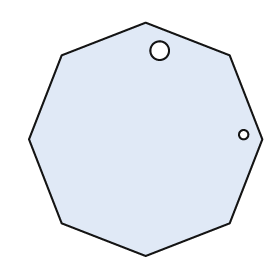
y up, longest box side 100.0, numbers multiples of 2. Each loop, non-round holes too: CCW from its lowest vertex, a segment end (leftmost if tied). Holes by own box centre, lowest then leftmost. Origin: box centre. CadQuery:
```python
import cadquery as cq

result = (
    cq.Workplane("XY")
    .moveTo(0.0, -50.0)
    .lineTo(36.0, -36.0)
    .lineTo(50.0, 0.0)
    .lineTo(36.0, 36.0)
    .lineTo(0.0, 50.0)
    .lineTo(-36.0, 36.0)
    .lineTo(-50.0, 0.0)
    .lineTo(-36.0, -36.0)
    .close()
    .moveTo(42.0, 2.0)
    .circle(2.0)
    .moveTo(6.0, 38.0)
    .circle(4.0)
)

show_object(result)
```